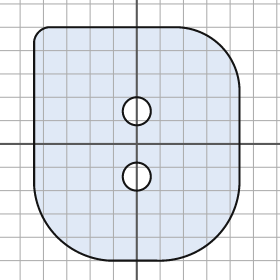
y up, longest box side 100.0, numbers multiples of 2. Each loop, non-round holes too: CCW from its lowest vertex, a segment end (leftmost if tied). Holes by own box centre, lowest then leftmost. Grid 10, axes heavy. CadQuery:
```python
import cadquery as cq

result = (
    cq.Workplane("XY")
    .moveTo(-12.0, -50.0)
    .lineTo(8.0, -50.0)
    .threePointArc((34.0, -40.0), (44.0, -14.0))
    .lineTo(44.0, 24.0)
    .threePointArc((36.0, 42.0), (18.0, 50.0))
    .lineTo(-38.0, 50.0)
    .threePointArc((-42.0, 48.0), (-44.0, 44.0))
    .lineTo(-44.0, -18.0)
    .threePointArc((-34.0, -40.0), (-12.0, -50.0))
    .close()
    .moveTo(0.0, -14.0)
    .circle(6.0)
    .moveTo(0.0, 14.0)
    .circle(6.0)
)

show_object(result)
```